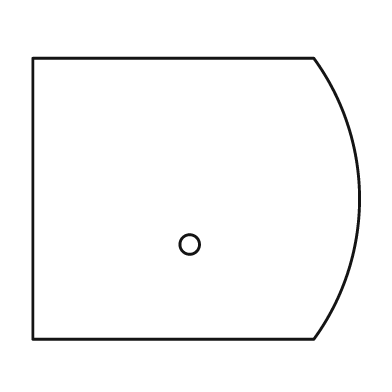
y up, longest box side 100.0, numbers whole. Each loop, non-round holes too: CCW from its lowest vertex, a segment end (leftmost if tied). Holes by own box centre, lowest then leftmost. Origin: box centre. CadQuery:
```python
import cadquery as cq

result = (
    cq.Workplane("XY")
    .moveTo(-50.0, -43.0)
    .lineTo(36.0, -43.0)
    .threePointArc((50.0, 0.0), (36.0, 43.0))
    .lineTo(-50.0, 43.0)
    .close()
    .moveTo(-2.0, -14.0)
    .circle(3.0)
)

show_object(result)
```